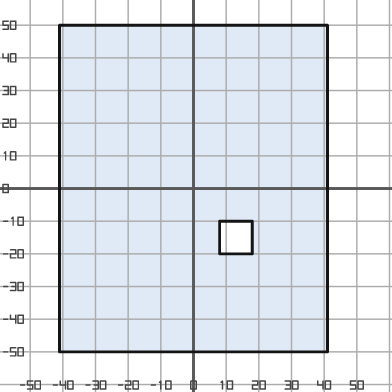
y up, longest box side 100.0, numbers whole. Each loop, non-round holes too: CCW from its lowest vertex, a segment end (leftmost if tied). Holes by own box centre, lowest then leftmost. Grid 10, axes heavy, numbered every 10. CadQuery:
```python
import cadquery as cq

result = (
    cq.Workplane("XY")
    .moveTo(-41.0, -50.0)
    .lineTo(41.0, -50.0)
    .lineTo(41.0, 50.0)
    .lineTo(-41.0, 50.0)
    .close()
    .moveTo(8.0, -20.0)
    .lineTo(18.0, -20.0)
    .lineTo(18.0, -10.0)
    .lineTo(8.0, -10.0)
    .close()
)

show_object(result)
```